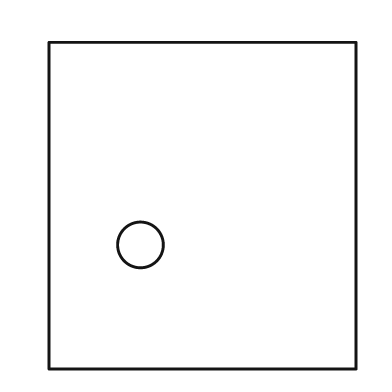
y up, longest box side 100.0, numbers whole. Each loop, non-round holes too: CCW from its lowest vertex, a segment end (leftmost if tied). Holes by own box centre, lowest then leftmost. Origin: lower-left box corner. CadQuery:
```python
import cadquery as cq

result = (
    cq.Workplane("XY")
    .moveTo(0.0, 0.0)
    .lineTo(94.0, 0.0)
    .lineTo(94.0, 100.0)
    .lineTo(0.0, 100.0)
    .close()
    .moveTo(28.0, 38.0)
    .circle(7.0)
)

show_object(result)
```